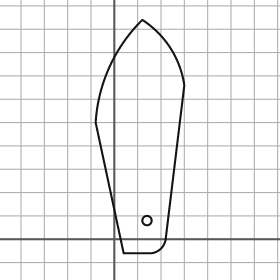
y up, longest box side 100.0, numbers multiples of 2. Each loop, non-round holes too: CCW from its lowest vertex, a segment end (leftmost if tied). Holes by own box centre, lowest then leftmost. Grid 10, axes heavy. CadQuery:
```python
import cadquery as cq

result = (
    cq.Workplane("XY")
    .moveTo(4.0, -6.0)
    .lineTo(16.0, -6.0)
    .threePointArc((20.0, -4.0), (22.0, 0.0))
    .lineTo(30.0, 66.0)
    .threePointArc((24.0, 82.0), (12.0, 94.0))
    .threePointArc((-2.0, 74.0), (-8.0, 50.0))
    .close()
    .moveTo(14.0, 8.0)
    .circle(2.0)
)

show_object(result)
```